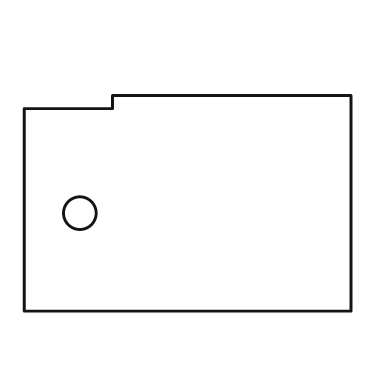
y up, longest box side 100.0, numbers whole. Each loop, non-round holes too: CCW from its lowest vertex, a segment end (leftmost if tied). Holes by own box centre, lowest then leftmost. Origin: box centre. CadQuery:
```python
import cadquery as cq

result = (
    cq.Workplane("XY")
    .moveTo(-50.0, -33.0)
    .lineTo(50.0, -33.0)
    .lineTo(50.0, 33.0)
    .lineTo(-23.0, 33.0)
    .lineTo(-23.0, 29.0)
    .lineTo(-50.0, 29.0)
    .close()
    .moveTo(-33.0, -3.0)
    .circle(5.0)
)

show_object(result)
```